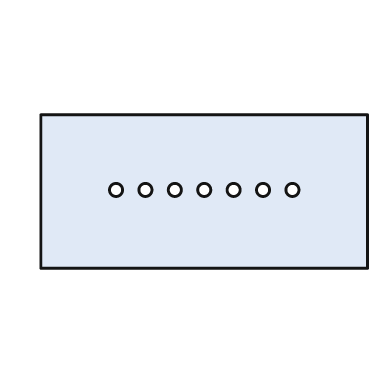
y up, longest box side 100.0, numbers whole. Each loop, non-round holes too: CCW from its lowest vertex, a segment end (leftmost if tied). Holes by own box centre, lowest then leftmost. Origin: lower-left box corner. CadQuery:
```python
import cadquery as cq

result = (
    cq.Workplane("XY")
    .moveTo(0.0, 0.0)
    .lineTo(100.0, 0.0)
    .lineTo(100.0, 47.0)
    .lineTo(0.0, 47.0)
    .close()
    .moveTo(23.0, 24.0)
    .circle(2.0)
    .moveTo(32.0, 24.0)
    .circle(2.0)
    .moveTo(41.0, 24.0)
    .circle(2.0)
    .moveTo(50.0, 24.0)
    .circle(2.0)
    .moveTo(59.0, 24.0)
    .circle(2.0)
    .moveTo(68.0, 24.0)
    .circle(2.0)
    .moveTo(77.0, 24.0)
    .circle(2.0)
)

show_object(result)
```